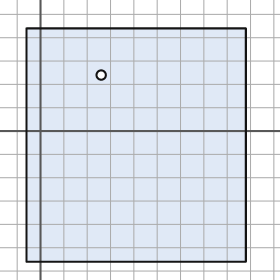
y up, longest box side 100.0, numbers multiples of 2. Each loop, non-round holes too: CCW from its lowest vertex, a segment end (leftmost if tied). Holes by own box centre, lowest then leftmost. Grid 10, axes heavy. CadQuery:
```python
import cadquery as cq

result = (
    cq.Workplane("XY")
    .moveTo(-6.0, -56.0)
    .lineTo(88.0, -56.0)
    .lineTo(88.0, 44.0)
    .lineTo(-6.0, 44.0)
    .close()
    .moveTo(26.0, 24.0)
    .circle(2.0)
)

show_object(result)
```